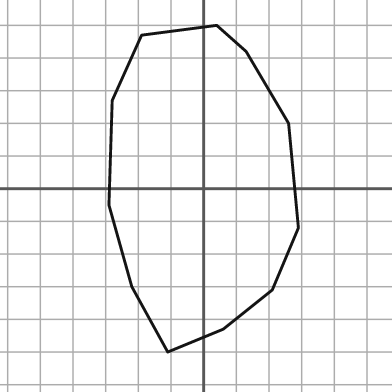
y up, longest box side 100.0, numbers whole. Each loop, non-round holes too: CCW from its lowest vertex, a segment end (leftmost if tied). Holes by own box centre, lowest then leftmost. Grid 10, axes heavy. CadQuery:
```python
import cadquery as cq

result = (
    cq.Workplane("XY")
    .moveTo(-11.0, -50.0)
    .lineTo(6.0, -43.0)
    .lineTo(21.0, -31.0)
    .lineTo(29.0, -12.0)
    .lineTo(26.0, 20.0)
    .lineTo(13.0, 42.0)
    .lineTo(4.0, 50.0)
    .lineTo(-19.0, 47.0)
    .lineTo(-28.0, 27.0)
    .lineTo(-29.0, -5.0)
    .lineTo(-22.0, -30.0)
    .close()
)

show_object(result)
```